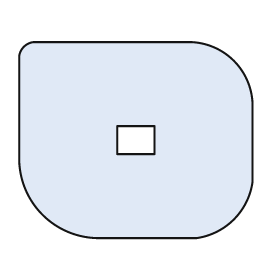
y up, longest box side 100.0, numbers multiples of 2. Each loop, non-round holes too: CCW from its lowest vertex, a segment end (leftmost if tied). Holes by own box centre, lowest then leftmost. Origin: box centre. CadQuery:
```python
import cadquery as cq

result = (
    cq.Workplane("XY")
    .moveTo(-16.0, -42.0)
    .lineTo(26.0, -42.0)
    .threePointArc((42.0, -34.0), (50.0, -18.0))
    .lineTo(50.0, 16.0)
    .threePointArc((42.0, 34.0), (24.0, 42.0))
    .lineTo(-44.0, 42.0)
    .threePointArc((-48.0, 40.0), (-50.0, 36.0))
    .lineTo(-50.0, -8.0)
    .threePointArc((-40.0, -32.0), (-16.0, -42.0))
    .close()
    .moveTo(-8.0, -6.0)
    .lineTo(8.0, -6.0)
    .lineTo(8.0, 6.0)
    .lineTo(-8.0, 6.0)
    .close()
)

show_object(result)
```